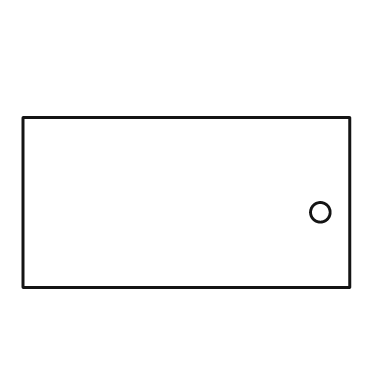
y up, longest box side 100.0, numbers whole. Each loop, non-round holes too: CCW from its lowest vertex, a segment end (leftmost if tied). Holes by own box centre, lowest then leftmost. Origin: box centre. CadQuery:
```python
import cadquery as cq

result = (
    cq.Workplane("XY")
    .moveTo(-50.0, -26.0)
    .lineTo(50.0, -26.0)
    .lineTo(50.0, 26.0)
    .lineTo(-50.0, 26.0)
    .close()
    .moveTo(41.0, -3.0)
    .circle(3.0)
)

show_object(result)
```